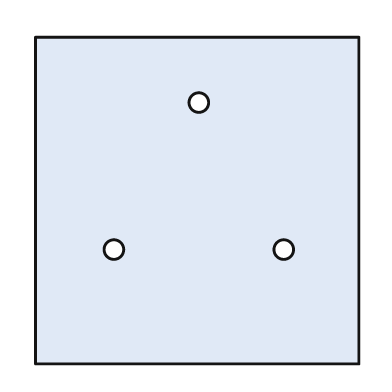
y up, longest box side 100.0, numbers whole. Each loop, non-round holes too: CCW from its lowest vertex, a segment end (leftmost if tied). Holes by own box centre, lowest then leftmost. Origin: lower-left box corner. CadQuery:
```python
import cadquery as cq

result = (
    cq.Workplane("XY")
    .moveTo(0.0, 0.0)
    .lineTo(99.0, 0.0)
    .lineTo(99.0, 100.0)
    .lineTo(0.0, 100.0)
    .close()
    .moveTo(24.0, 35.0)
    .circle(3.0)
    .moveTo(76.0, 35.0)
    .circle(3.0)
    .moveTo(50.0, 80.0)
    .circle(3.0)
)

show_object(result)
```